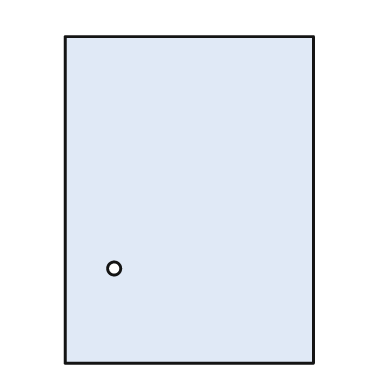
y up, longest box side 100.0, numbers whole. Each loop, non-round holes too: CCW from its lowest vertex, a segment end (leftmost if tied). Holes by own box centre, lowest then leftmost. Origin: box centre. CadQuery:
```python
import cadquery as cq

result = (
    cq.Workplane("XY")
    .moveTo(-38.0, -50.0)
    .lineTo(38.0, -50.0)
    .lineTo(38.0, 50.0)
    .lineTo(-38.0, 50.0)
    .close()
    .moveTo(-23.0, -21.0)
    .circle(2.0)
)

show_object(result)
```